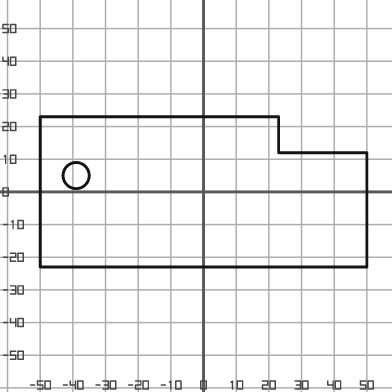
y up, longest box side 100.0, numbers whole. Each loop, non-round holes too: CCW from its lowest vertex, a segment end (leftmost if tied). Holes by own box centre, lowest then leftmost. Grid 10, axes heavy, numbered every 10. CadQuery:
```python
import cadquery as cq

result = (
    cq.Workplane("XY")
    .moveTo(-50.0, -23.0)
    .lineTo(50.0, -23.0)
    .lineTo(50.0, 12.0)
    .lineTo(23.0, 12.0)
    .lineTo(23.0, 23.0)
    .lineTo(-50.0, 23.0)
    .close()
    .moveTo(-39.0, 5.0)
    .circle(4.0)
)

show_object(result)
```